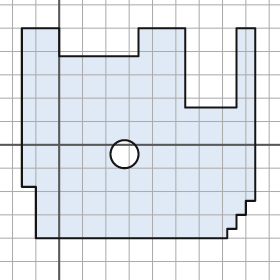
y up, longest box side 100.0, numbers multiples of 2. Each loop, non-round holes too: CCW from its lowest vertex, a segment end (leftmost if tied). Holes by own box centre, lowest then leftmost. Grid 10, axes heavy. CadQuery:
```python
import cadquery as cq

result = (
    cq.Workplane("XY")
    .moveTo(-10.0, -40.0)
    .lineTo(72.0, -40.0)
    .lineTo(72.0, -36.0)
    .lineTo(76.0, -36.0)
    .lineTo(76.0, -30.0)
    .lineTo(80.0, -30.0)
    .lineTo(80.0, -24.0)
    .lineTo(84.0, -24.0)
    .lineTo(84.0, 50.0)
    .lineTo(76.0, 50.0)
    .lineTo(76.0, 16.0)
    .lineTo(54.0, 16.0)
    .lineTo(54.0, 50.0)
    .lineTo(34.0, 50.0)
    .lineTo(34.0, 38.0)
    .lineTo(0.0, 38.0)
    .lineTo(0.0, 50.0)
    .lineTo(-16.0, 50.0)
    .lineTo(-16.0, -18.0)
    .lineTo(-10.0, -18.0)
    .close()
    .moveTo(28.0, -4.0)
    .circle(6.0)
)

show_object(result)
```